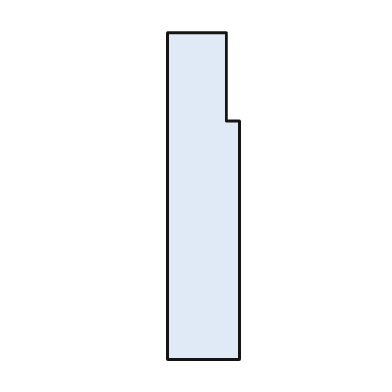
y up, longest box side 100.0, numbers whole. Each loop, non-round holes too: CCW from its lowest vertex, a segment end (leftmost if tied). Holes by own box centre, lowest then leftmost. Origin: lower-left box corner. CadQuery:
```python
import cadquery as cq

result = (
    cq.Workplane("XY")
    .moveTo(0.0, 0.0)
    .lineTo(22.0, 0.0)
    .lineTo(22.0, 73.0)
    .lineTo(18.0, 73.0)
    .lineTo(18.0, 100.0)
    .lineTo(0.0, 100.0)
    .close()
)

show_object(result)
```